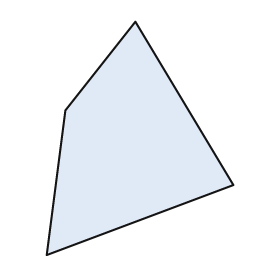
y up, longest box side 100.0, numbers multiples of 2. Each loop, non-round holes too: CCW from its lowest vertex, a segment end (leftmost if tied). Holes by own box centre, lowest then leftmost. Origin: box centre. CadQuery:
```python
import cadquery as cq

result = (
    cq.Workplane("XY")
    .moveTo(-40.0, -50.0)
    .lineTo(40.0, -20.0)
    .lineTo(-2.0, 50.0)
    .lineTo(-32.0, 12.0)
    .close()
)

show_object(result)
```